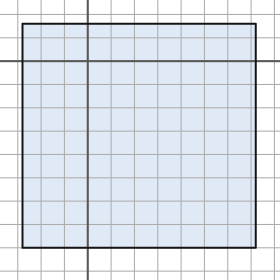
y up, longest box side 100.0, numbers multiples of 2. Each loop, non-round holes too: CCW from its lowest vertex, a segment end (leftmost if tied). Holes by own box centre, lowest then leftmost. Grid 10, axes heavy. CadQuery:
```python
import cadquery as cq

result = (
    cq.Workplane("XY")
    .moveTo(-28.0, -80.0)
    .lineTo(72.0, -80.0)
    .lineTo(72.0, 16.0)
    .lineTo(-28.0, 16.0)
    .close()
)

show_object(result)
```